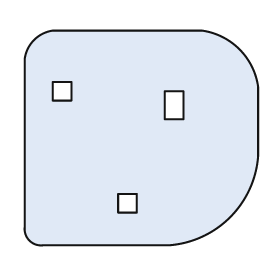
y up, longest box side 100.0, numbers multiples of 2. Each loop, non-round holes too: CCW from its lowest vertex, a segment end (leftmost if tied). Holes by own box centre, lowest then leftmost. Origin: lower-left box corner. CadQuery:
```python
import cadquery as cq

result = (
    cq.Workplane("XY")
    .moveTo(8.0, 0.0)
    .lineTo(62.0, 0.0)
    .threePointArc((88.0, 12.0), (100.0, 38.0))
    .lineTo(100.0, 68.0)
    .threePointArc((92.0, 84.0), (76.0, 92.0))
    .lineTo(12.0, 92.0)
    .threePointArc((4.0, 88.0), (0.0, 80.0))
    .lineTo(0.0, 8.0)
    .threePointArc((2.0, 2.0), (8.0, 0.0))
    .close()
    .moveTo(40.0, 14.0)
    .lineTo(48.0, 14.0)
    .lineTo(48.0, 22.0)
    .lineTo(40.0, 22.0)
    .close()
    .moveTo(60.0, 54.0)
    .lineTo(68.0, 54.0)
    .lineTo(68.0, 66.0)
    .lineTo(60.0, 66.0)
    .close()
    .moveTo(12.0, 62.0)
    .lineTo(20.0, 62.0)
    .lineTo(20.0, 70.0)
    .lineTo(12.0, 70.0)
    .close()
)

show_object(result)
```